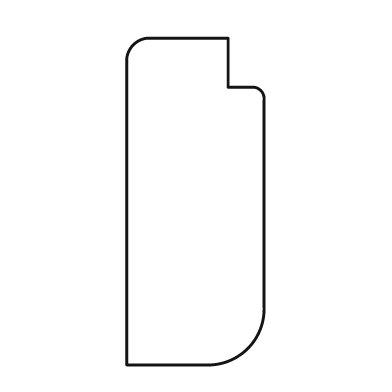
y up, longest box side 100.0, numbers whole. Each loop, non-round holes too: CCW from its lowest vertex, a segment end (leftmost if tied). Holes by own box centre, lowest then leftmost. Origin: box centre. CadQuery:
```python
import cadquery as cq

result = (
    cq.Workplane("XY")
    .moveTo(-21.0, -50.0)
    .lineTo(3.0, -50.0)
    .threePointArc((16.0, -45.0), (21.0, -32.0))
    .lineTo(21.0, 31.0)
    .threePointArc((20.0, 34.0), (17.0, 35.0))
    .lineTo(10.0, 35.0)
    .lineTo(10.0, 50.0)
    .lineTo(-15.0, 50.0)
    .threePointArc((-19.0, 48.0), (-21.0, 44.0))
    .close()
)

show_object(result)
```